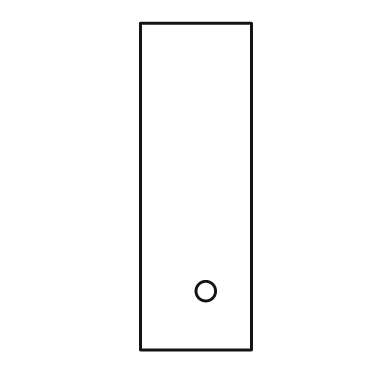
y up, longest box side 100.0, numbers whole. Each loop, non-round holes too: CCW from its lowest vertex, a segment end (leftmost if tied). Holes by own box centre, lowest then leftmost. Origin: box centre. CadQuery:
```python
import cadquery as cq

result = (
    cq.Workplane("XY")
    .moveTo(-17.0, -50.0)
    .lineTo(17.0, -50.0)
    .lineTo(17.0, 50.0)
    .lineTo(-17.0, 50.0)
    .close()
    .moveTo(3.0, -32.0)
    .circle(3.0)
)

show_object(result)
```